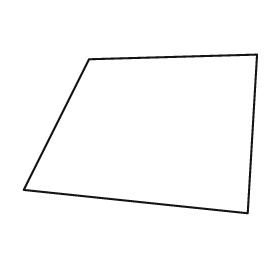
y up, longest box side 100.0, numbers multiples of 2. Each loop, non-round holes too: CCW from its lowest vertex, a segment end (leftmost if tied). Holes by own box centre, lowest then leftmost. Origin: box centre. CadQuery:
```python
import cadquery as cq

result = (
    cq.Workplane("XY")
    .moveTo(46.0, -34.0)
    .lineTo(50.0, 34.0)
    .lineTo(-22.0, 32.0)
    .lineTo(-50.0, -24.0)
    .close()
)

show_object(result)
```